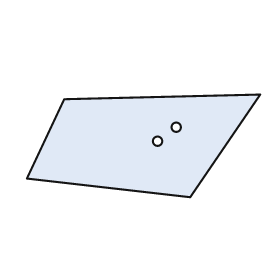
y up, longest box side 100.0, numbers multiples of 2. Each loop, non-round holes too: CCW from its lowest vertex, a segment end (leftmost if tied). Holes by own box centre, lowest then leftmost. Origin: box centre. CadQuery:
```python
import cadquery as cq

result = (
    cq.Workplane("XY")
    .moveTo(20.0, -22.0)
    .lineTo(50.0, 22.0)
    .lineTo(-34.0, 20.0)
    .lineTo(-50.0, -14.0)
    .close()
    .moveTo(6.0, 2.0)
    .circle(2.0)
    .moveTo(14.0, 8.0)
    .circle(2.0)
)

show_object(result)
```